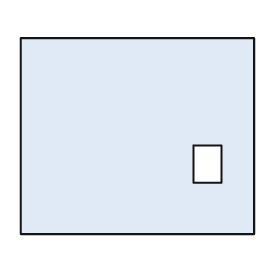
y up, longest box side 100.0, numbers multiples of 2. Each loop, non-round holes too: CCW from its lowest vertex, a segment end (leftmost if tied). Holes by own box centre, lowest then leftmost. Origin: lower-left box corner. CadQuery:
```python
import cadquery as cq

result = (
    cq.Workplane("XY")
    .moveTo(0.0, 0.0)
    .lineTo(100.0, 0.0)
    .lineTo(100.0, 84.0)
    .lineTo(0.0, 84.0)
    .close()
    .moveTo(74.0, 22.0)
    .lineTo(86.0, 22.0)
    .lineTo(86.0, 38.0)
    .lineTo(74.0, 38.0)
    .close()
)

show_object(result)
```